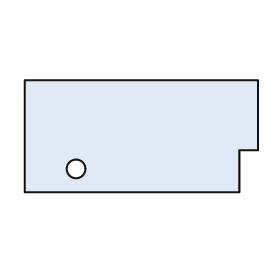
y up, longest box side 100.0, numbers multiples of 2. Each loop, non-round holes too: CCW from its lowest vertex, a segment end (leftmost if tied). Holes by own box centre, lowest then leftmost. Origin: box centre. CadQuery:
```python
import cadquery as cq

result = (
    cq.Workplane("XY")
    .moveTo(-50.0, -24.0)
    .lineTo(42.0, -24.0)
    .lineTo(42.0, -6.0)
    .lineTo(50.0, -6.0)
    .lineTo(50.0, 24.0)
    .lineTo(-50.0, 24.0)
    .close()
    .moveTo(-28.0, -14.0)
    .circle(4.0)
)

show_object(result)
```